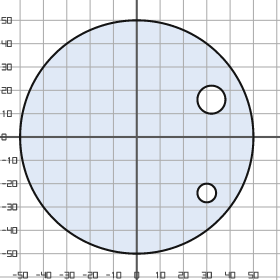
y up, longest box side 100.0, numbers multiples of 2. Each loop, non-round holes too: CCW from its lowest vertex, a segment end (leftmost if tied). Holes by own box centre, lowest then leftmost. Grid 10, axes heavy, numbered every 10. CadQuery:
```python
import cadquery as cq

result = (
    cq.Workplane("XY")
    .moveTo(0.0, 0.0)
    .circle(50.0)
    .moveTo(30.0, -24.0)
    .circle(4.0)
    .moveTo(32.0, 16.0)
    .circle(6.0)
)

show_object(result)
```